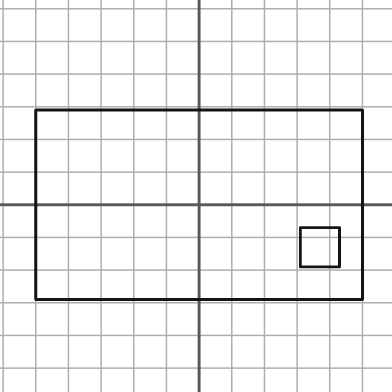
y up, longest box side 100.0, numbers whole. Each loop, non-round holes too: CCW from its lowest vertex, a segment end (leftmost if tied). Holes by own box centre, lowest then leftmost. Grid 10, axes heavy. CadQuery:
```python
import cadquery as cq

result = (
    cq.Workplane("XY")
    .moveTo(-50.0, -29.0)
    .lineTo(50.0, -29.0)
    .lineTo(50.0, 29.0)
    .lineTo(-50.0, 29.0)
    .close()
    .moveTo(31.0, -19.0)
    .lineTo(43.0, -19.0)
    .lineTo(43.0, -7.0)
    .lineTo(31.0, -7.0)
    .close()
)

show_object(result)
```